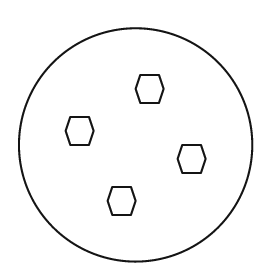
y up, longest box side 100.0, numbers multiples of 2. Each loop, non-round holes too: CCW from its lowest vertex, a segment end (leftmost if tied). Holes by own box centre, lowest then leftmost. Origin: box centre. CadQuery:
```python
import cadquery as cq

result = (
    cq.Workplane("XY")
    .moveTo(0.0, 0.0)
    .circle(50.0)
    .moveTo(-10.0, -30.0)
    .lineTo(-2.0, -30.0)
    .lineTo(0.0, -24.0)
    .lineTo(-2.0, -18.0)
    .lineTo(-10.0, -18.0)
    .lineTo(-12.0, -24.0)
    .close()
    .moveTo(20.0, -12.0)
    .lineTo(28.0, -12.0)
    .lineTo(30.0, -6.0)
    .lineTo(28.0, 0.0)
    .lineTo(20.0, 0.0)
    .lineTo(18.0, -6.0)
    .close()
    .moveTo(-28.0, 0.0)
    .lineTo(-20.0, 0.0)
    .lineTo(-18.0, 6.0)
    .lineTo(-20.0, 12.0)
    .lineTo(-28.0, 12.0)
    .lineTo(-30.0, 6.0)
    .close()
    .moveTo(2.0, 18.0)
    .lineTo(10.0, 18.0)
    .lineTo(12.0, 24.0)
    .lineTo(10.0, 30.0)
    .lineTo(2.0, 30.0)
    .lineTo(0.0, 24.0)
    .close()
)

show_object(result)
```